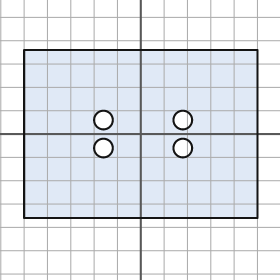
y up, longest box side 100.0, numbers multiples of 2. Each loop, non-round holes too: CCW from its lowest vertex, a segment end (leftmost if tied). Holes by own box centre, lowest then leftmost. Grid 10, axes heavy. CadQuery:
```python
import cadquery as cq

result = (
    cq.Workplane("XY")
    .moveTo(-50.0, -36.0)
    .lineTo(50.0, -36.0)
    .lineTo(50.0, 36.0)
    .lineTo(-50.0, 36.0)
    .close()
    .moveTo(-16.0, -6.0)
    .circle(4.0)
    .moveTo(18.0, -6.0)
    .circle(4.0)
    .moveTo(-16.0, 6.0)
    .circle(4.0)
    .moveTo(18.0, 6.0)
    .circle(4.0)
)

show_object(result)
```